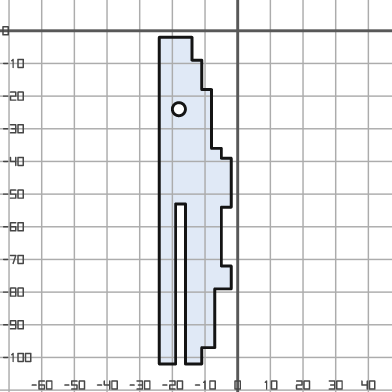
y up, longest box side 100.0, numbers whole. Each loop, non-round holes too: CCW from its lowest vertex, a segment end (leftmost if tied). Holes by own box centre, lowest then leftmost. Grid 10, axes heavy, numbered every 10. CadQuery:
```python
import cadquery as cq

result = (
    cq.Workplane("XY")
    .moveTo(-24.0, -102.0)
    .lineTo(-19.0, -102.0)
    .lineTo(-19.0, -53.0)
    .lineTo(-16.0, -53.0)
    .lineTo(-16.0, -102.0)
    .lineTo(-11.0, -102.0)
    .lineTo(-11.0, -97.0)
    .lineTo(-7.0, -97.0)
    .lineTo(-7.0, -79.0)
    .lineTo(-2.0, -79.0)
    .lineTo(-2.0, -72.0)
    .lineTo(-5.0, -72.0)
    .lineTo(-5.0, -54.0)
    .lineTo(-2.0, -54.0)
    .lineTo(-2.0, -39.0)
    .lineTo(-5.0, -39.0)
    .lineTo(-5.0, -36.0)
    .lineTo(-8.0, -36.0)
    .lineTo(-8.0, -18.0)
    .lineTo(-11.0, -18.0)
    .lineTo(-11.0, -9.0)
    .lineTo(-14.0, -9.0)
    .lineTo(-14.0, -2.0)
    .lineTo(-24.0, -2.0)
    .close()
    .moveTo(-18.0, -24.0)
    .circle(2.0)
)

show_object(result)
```